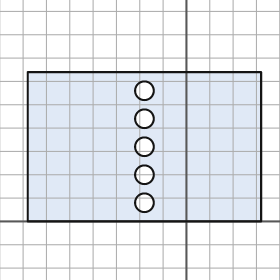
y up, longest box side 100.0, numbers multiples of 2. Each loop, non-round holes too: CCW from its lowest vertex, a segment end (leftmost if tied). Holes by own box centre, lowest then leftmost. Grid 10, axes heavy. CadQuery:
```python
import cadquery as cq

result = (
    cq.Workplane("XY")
    .moveTo(-68.0, 0.0)
    .lineTo(32.0, 0.0)
    .lineTo(32.0, 64.0)
    .lineTo(-68.0, 64.0)
    .close()
    .moveTo(-18.0, 8.0)
    .circle(4.0)
    .moveTo(-18.0, 20.0)
    .circle(4.0)
    .moveTo(-18.0, 32.0)
    .circle(4.0)
    .moveTo(-18.0, 44.0)
    .circle(4.0)
    .moveTo(-18.0, 56.0)
    .circle(4.0)
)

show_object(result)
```